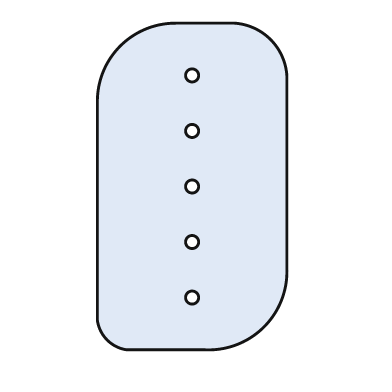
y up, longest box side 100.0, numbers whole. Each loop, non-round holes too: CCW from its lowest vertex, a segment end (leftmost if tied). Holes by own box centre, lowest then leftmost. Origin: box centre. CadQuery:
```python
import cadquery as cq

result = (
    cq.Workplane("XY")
    .moveTo(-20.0, -50.0)
    .lineTo(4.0, -50.0)
    .threePointArc((22.0, -43.0), (29.0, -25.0))
    .lineTo(29.0, 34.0)
    .threePointArc((24.0, 45.0), (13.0, 50.0))
    .lineTo(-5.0, 50.0)
    .threePointArc((-22.0, 43.0), (-29.0, 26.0))
    .lineTo(-29.0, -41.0)
    .threePointArc((-26.0, -47.0), (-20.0, -50.0))
    .close()
    .moveTo(0.0, -34.0)
    .circle(2.0)
    .moveTo(0.0, -17.0)
    .circle(2.0)
    .moveTo(0.0, 0.0)
    .circle(2.0)
    .moveTo(0.0, 17.0)
    .circle(2.0)
    .moveTo(0.0, 34.0)
    .circle(2.0)
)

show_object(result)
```